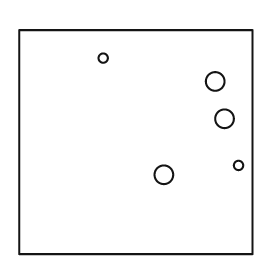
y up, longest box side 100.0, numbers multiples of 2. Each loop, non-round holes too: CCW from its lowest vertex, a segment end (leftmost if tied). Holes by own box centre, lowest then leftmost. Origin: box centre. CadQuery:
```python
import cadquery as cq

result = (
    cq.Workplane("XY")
    .moveTo(-50.0, -48.0)
    .lineTo(50.0, -48.0)
    .lineTo(50.0, 48.0)
    .lineTo(-50.0, 48.0)
    .close()
    .moveTo(12.0, -14.0)
    .circle(4.0)
    .moveTo(44.0, -10.0)
    .circle(2.0)
    .moveTo(38.0, 10.0)
    .circle(4.0)
    .moveTo(34.0, 26.0)
    .circle(4.0)
    .moveTo(-14.0, 36.0)
    .circle(2.0)
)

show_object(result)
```